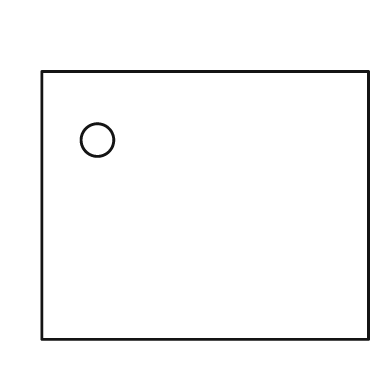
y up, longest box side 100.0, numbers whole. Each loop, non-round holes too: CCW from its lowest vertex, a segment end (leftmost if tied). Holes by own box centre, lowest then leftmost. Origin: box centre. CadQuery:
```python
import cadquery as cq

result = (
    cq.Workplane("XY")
    .moveTo(-50.0, -41.0)
    .lineTo(50.0, -41.0)
    .lineTo(50.0, 41.0)
    .lineTo(-50.0, 41.0)
    .close()
    .moveTo(-33.0, 20.0)
    .circle(5.0)
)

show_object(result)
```